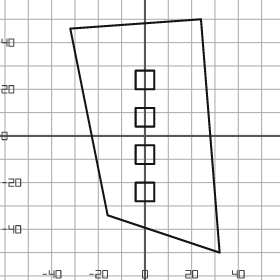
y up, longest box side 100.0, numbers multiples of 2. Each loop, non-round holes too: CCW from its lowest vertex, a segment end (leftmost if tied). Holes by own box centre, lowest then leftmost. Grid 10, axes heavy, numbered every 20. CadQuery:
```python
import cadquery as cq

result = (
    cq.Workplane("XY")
    .moveTo(32.0, -50.0)
    .lineTo(24.0, 50.0)
    .lineTo(-32.0, 46.0)
    .lineTo(-16.0, -34.0)
    .close()
    .moveTo(-4.0, -28.0)
    .lineTo(4.0, -28.0)
    .lineTo(4.0, -20.0)
    .lineTo(-4.0, -20.0)
    .close()
    .moveTo(-4.0, -12.0)
    .lineTo(4.0, -12.0)
    .lineTo(4.0, -4.0)
    .lineTo(-4.0, -4.0)
    .close()
    .moveTo(-4.0, 4.0)
    .lineTo(4.0, 4.0)
    .lineTo(4.0, 12.0)
    .lineTo(-4.0, 12.0)
    .close()
    .moveTo(-4.0, 20.0)
    .lineTo(4.0, 20.0)
    .lineTo(4.0, 28.0)
    .lineTo(-4.0, 28.0)
    .close()
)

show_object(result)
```